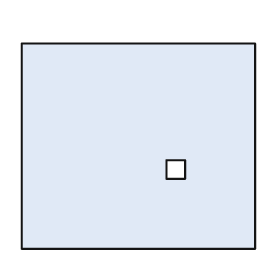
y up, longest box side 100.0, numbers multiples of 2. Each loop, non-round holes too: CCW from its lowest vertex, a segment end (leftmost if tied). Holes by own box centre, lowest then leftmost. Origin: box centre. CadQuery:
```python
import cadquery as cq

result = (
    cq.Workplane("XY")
    .moveTo(-50.0, -44.0)
    .lineTo(50.0, -44.0)
    .lineTo(50.0, 44.0)
    .lineTo(-50.0, 44.0)
    .close()
    .moveTo(12.0, -14.0)
    .lineTo(20.0, -14.0)
    .lineTo(20.0, -6.0)
    .lineTo(12.0, -6.0)
    .close()
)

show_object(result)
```